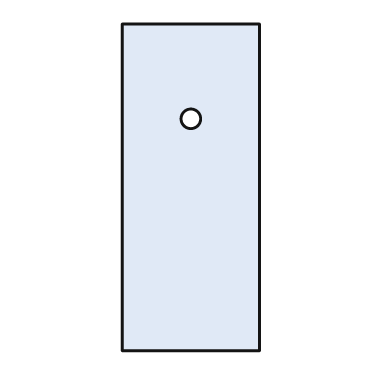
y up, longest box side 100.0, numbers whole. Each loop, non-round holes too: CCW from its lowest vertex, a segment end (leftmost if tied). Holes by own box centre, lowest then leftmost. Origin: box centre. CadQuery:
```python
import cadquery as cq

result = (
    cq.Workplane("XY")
    .moveTo(-21.0, -50.0)
    .lineTo(21.0, -50.0)
    .lineTo(21.0, 50.0)
    .lineTo(-21.0, 50.0)
    .close()
    .moveTo(0.0, 21.0)
    .circle(3.0)
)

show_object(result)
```